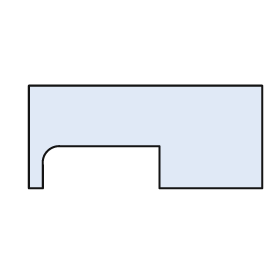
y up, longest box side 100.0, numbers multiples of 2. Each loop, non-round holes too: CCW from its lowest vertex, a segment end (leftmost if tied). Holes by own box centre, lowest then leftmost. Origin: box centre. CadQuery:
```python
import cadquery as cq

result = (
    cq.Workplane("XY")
    .moveTo(-50.0, -22.0)
    .lineTo(-44.0, -22.0)
    .lineTo(-44.0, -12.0)
    .threePointArc((-42.0, -6.0), (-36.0, -4.0))
    .lineTo(6.0, -4.0)
    .lineTo(6.0, -22.0)
    .lineTo(50.0, -22.0)
    .lineTo(50.0, 22.0)
    .lineTo(-50.0, 22.0)
    .close()
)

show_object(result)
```